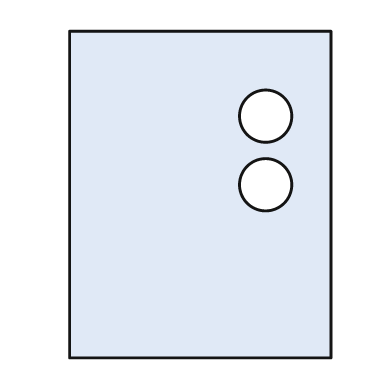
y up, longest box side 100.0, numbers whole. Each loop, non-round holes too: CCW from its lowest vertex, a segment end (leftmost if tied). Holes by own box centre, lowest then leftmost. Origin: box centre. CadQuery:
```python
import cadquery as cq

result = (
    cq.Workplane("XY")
    .moveTo(-40.0, -50.0)
    .lineTo(40.0, -50.0)
    .lineTo(40.0, 50.0)
    .lineTo(-40.0, 50.0)
    .close()
    .moveTo(20.0, 3.0)
    .circle(8.0)
    .moveTo(20.0, 24.0)
    .circle(8.0)
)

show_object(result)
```